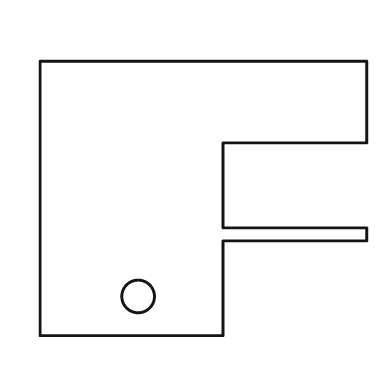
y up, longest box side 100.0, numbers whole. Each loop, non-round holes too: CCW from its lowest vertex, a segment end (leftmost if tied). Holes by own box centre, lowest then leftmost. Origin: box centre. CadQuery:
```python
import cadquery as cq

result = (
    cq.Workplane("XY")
    .moveTo(-50.0, -42.0)
    .lineTo(6.0, -42.0)
    .lineTo(6.0, -13.0)
    .lineTo(50.0, -13.0)
    .lineTo(50.0, -9.0)
    .lineTo(6.0, -9.0)
    .lineTo(6.0, 17.0)
    .lineTo(50.0, 17.0)
    .lineTo(50.0, 42.0)
    .lineTo(-50.0, 42.0)
    .close()
    .moveTo(-20.0, -30.0)
    .circle(5.0)
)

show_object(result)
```